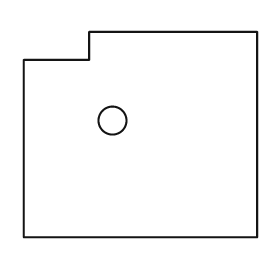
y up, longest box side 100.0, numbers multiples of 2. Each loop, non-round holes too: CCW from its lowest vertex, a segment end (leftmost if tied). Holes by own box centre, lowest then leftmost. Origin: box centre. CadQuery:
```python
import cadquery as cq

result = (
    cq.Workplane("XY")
    .moveTo(-50.0, -44.0)
    .lineTo(50.0, -44.0)
    .lineTo(50.0, 44.0)
    .lineTo(-22.0, 44.0)
    .lineTo(-22.0, 32.0)
    .lineTo(-50.0, 32.0)
    .close()
    .moveTo(-12.0, 6.0)
    .circle(6.0)
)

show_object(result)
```